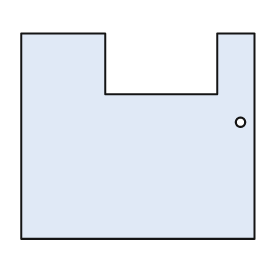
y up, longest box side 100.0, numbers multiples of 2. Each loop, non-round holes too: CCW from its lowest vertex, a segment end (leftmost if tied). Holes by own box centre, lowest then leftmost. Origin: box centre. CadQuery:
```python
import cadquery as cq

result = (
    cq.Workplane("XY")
    .moveTo(-50.0, -44.0)
    .lineTo(50.0, -44.0)
    .lineTo(50.0, 44.0)
    .lineTo(34.0, 44.0)
    .lineTo(34.0, 18.0)
    .lineTo(-14.0, 18.0)
    .lineTo(-14.0, 44.0)
    .lineTo(-50.0, 44.0)
    .close()
    .moveTo(44.0, 6.0)
    .circle(2.0)
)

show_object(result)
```